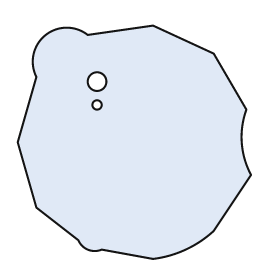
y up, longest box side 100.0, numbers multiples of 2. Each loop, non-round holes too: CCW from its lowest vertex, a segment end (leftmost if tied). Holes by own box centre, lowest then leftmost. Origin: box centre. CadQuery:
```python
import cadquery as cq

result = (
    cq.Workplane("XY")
    .moveTo(8.0, -50.0)
    .threePointArc((22.0, -46.0), (34.0, -38.0))
    .lineTo(50.0, -14.0)
    .threePointArc((46.0, 0.0), (48.0, 14.0))
    .lineTo(34.0, 38.0)
    .lineTo(8.0, 50.0)
    .lineTo(-20.0, 46.0)
    .threePointArc((-38.0, 46.0), (-42.0, 28.0))
    .lineTo(-50.0, 0.0)
    .lineTo(-42.0, -28.0)
    .lineTo(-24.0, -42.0)
    .threePointArc((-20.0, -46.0), (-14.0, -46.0))
    .close()
    .moveTo(-16.0, 16.0)
    .circle(2.0)
    .moveTo(-16.0, 26.0)
    .circle(4.0)
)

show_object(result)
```